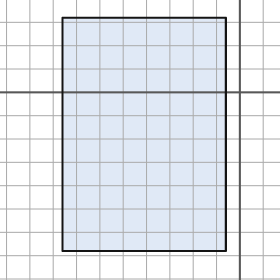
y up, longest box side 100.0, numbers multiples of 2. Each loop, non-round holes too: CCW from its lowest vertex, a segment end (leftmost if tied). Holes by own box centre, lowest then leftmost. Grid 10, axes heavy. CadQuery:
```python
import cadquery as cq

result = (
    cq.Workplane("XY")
    .moveTo(-76.0, -68.0)
    .lineTo(-6.0, -68.0)
    .lineTo(-6.0, 32.0)
    .lineTo(-76.0, 32.0)
    .close()
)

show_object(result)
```